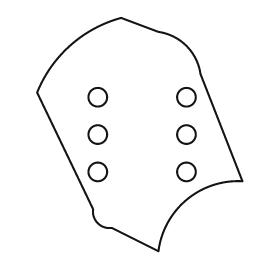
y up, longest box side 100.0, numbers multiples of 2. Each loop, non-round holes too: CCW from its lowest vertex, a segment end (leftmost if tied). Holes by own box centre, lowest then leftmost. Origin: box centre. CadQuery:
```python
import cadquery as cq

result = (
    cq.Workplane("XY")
    .moveTo(8.0, -50.0)
    .threePointArc((20.0, -28.0), (44.0, -20.0))
    .lineTo(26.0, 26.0)
    .threePointArc((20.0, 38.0), (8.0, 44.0))
    .lineTo(-8.0, 50.0)
    .threePointArc((-30.0, 38.0), (-44.0, 18.0))
    .lineTo(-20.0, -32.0)
    .threePointArc((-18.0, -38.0), (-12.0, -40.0))
    .close()
    .moveTo(-18.0, -16.0)
    .circle(4.0)
    .moveTo(20.0, -16.0)
    .circle(4.0)
    .moveTo(-18.0, 0.0)
    .circle(4.0)
    .moveTo(20.0, 0.0)
    .circle(4.0)
    .moveTo(-18.0, 16.0)
    .circle(4.0)
    .moveTo(20.0, 16.0)
    .circle(4.0)
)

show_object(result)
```